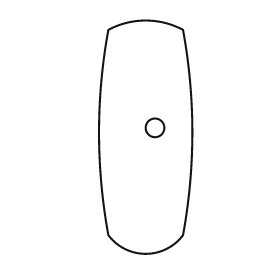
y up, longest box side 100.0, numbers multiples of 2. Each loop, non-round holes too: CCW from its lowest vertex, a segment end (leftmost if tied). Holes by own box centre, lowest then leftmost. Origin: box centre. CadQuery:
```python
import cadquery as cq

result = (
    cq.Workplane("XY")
    .moveTo(-16.0, -42.0)
    .threePointArc((0.0, -50.0), (16.0, -42.0))
    .threePointArc((20.0, 2.0), (16.0, 46.0))
    .threePointArc((0.0, 50.0), (-16.0, 46.0))
    .threePointArc((-20.0, 2.0), (-16.0, -42.0))
    .close()
    .moveTo(4.0, 4.0)
    .circle(4.0)
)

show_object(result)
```